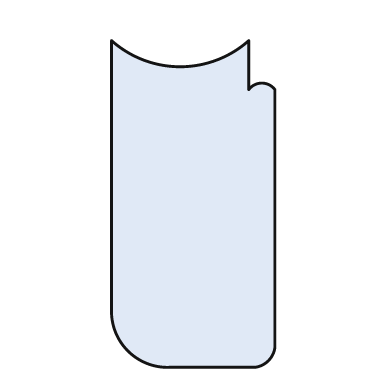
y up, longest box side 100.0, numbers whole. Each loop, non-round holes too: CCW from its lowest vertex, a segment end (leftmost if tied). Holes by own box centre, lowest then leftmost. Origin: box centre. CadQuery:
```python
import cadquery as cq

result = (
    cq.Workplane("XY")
    .moveTo(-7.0, -50.0)
    .lineTo(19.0, -50.0)
    .threePointArc((23.0, -48.0), (25.0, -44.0))
    .lineTo(25.0, 35.0)
    .threePointArc((21.0, 37.0), (17.0, 35.0))
    .lineTo(17.0, 50.0)
    .threePointArc((-4.0, 42.0), (-25.0, 50.0))
    .lineTo(-25.0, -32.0)
    .threePointArc((-20.0, -45.0), (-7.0, -50.0))
    .close()
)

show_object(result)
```